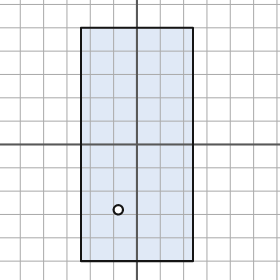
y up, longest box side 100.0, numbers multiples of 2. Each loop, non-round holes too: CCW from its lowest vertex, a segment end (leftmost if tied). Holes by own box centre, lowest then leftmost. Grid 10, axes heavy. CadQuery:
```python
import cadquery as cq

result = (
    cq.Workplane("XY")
    .moveTo(-24.0, -50.0)
    .lineTo(24.0, -50.0)
    .lineTo(24.0, 50.0)
    .lineTo(-24.0, 50.0)
    .close()
    .moveTo(-8.0, -28.0)
    .circle(2.0)
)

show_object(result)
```